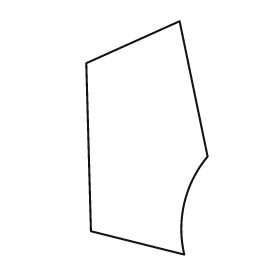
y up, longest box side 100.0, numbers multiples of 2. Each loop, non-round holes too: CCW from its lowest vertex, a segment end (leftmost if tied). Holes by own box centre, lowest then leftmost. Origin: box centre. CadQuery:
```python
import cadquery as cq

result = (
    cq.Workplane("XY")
    .moveTo(16.0, -50.0)
    .threePointArc((16.0, -28.0), (26.0, -8.0))
    .lineTo(14.0, 50.0)
    .lineTo(-26.0, 32.0)
    .lineTo(-24.0, -40.0)
    .close()
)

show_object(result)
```